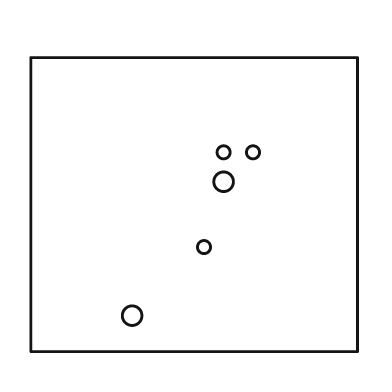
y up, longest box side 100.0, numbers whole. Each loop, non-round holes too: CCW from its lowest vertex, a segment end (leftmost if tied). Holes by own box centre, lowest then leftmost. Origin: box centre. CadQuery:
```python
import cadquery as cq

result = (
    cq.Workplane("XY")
    .moveTo(-50.0, -45.0)
    .lineTo(50.0, -45.0)
    .lineTo(50.0, 45.0)
    .lineTo(-50.0, 45.0)
    .close()
    .moveTo(-19.0, -34.0)
    .circle(3.0)
    .moveTo(3.0, -13.0)
    .circle(2.0)
    .moveTo(9.0, 7.0)
    .circle(3.0)
    .moveTo(9.0, 16.0)
    .circle(2.0)
    .moveTo(18.0, 16.0)
    .circle(2.0)
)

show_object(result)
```